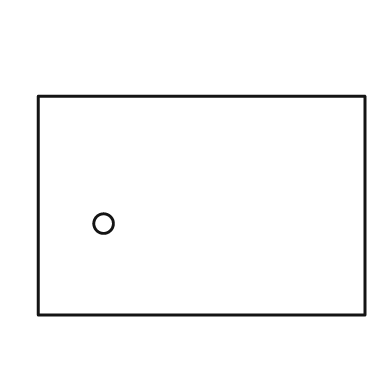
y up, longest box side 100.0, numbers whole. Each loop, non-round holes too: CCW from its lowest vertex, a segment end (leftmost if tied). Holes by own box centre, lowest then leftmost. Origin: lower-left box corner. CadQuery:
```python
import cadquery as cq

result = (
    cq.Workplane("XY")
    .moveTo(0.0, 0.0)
    .lineTo(100.0, 0.0)
    .lineTo(100.0, 67.0)
    .lineTo(0.0, 67.0)
    .close()
    .moveTo(20.0, 28.0)
    .circle(3.0)
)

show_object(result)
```